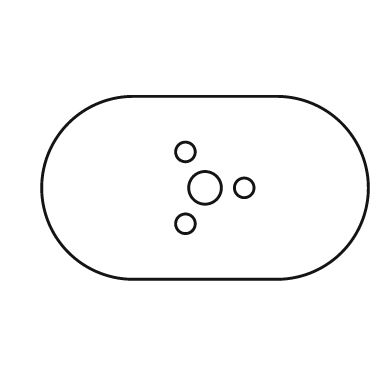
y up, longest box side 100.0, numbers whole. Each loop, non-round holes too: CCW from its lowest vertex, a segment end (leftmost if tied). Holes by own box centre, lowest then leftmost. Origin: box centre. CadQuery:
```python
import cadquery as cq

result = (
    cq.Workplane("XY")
    .moveTo(-22.0, -28.0)
    .lineTo(22.0, -28.0)
    .threePointArc((50.0, 0.0), (22.0, 28.0))
    .lineTo(-22.0, 28.0)
    .threePointArc((-50.0, 0.0), (-22.0, -28.0))
    .close()
    .moveTo(-6.0, -11.0)
    .circle(3.0)
    .moveTo(0.0, 0.0)
    .circle(5.0)
    .moveTo(12.0, 0.0)
    .circle(3.0)
    .moveTo(-6.0, 11.0)
    .circle(3.0)
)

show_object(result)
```